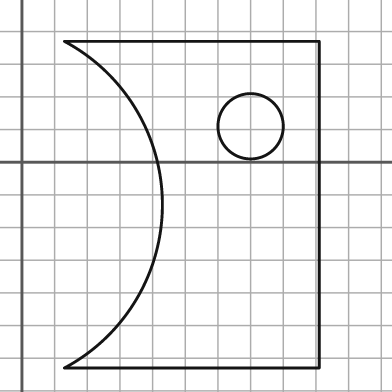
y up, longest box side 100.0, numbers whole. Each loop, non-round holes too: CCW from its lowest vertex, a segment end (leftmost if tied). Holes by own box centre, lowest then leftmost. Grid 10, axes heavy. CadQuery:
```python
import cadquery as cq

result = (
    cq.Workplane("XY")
    .moveTo(13.0, -63.0)
    .lineTo(91.0, -63.0)
    .lineTo(91.0, 37.0)
    .lineTo(13.0, 37.0)
    .threePointArc((43.0, -13.0), (13.0, -63.0))
    .close()
    .moveTo(70.0, 11.0)
    .circle(10.0)
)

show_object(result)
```